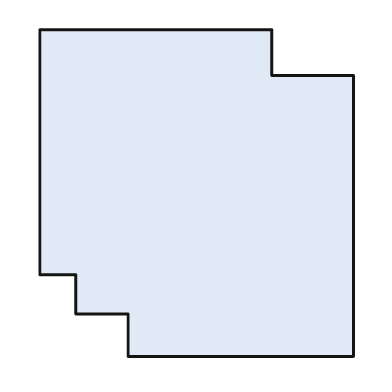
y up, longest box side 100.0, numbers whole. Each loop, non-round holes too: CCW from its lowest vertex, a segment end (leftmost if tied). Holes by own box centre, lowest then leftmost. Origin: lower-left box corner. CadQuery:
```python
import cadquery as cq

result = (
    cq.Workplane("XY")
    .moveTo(27.0, 0.0)
    .lineTo(96.0, 0.0)
    .lineTo(96.0, 86.0)
    .lineTo(71.0, 86.0)
    .lineTo(71.0, 100.0)
    .lineTo(0.0, 100.0)
    .lineTo(0.0, 25.0)
    .lineTo(11.0, 25.0)
    .lineTo(11.0, 13.0)
    .lineTo(27.0, 13.0)
    .close()
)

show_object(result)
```